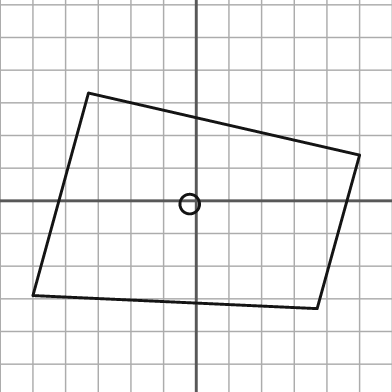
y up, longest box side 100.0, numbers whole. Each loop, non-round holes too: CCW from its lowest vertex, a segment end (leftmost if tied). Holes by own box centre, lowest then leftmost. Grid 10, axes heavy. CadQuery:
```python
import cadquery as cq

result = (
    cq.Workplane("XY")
    .moveTo(37.0, -33.0)
    .lineTo(50.0, 14.0)
    .lineTo(-33.0, 33.0)
    .lineTo(-50.0, -29.0)
    .close()
    .moveTo(-2.0, -1.0)
    .circle(3.0)
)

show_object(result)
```